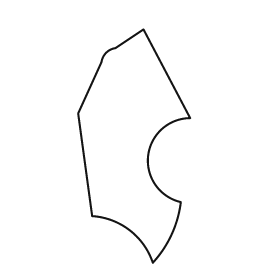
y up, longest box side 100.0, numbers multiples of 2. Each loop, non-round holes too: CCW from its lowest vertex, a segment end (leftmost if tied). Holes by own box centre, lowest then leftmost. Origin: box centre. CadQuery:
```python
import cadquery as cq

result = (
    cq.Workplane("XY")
    .moveTo(8.0, -50.0)
    .threePointArc((16.0, -38.0), (20.0, -24.0))
    .threePointArc((6.0, -4.0), (24.0, 12.0))
    .lineTo(4.0, 50.0)
    .lineTo(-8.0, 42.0)
    .threePointArc((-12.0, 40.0), (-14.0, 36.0))
    .lineTo(-24.0, 14.0)
    .lineTo(-18.0, -30.0)
    .threePointArc((-2.0, -36.0), (8.0, -50.0))
    .close()
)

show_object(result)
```